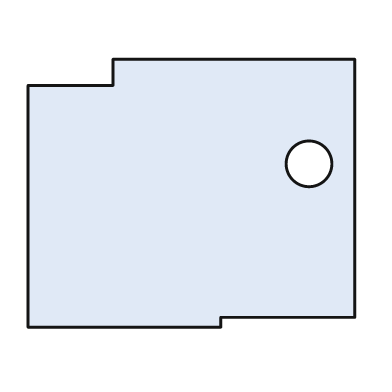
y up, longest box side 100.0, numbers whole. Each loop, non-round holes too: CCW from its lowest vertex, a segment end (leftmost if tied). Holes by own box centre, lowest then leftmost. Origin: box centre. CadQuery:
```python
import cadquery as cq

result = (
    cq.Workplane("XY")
    .moveTo(-50.0, -41.0)
    .lineTo(9.0, -41.0)
    .lineTo(9.0, -38.0)
    .lineTo(50.0, -38.0)
    .lineTo(50.0, 41.0)
    .lineTo(-24.0, 41.0)
    .lineTo(-24.0, 33.0)
    .lineTo(-50.0, 33.0)
    .close()
    .moveTo(36.0, 9.0)
    .circle(7.0)
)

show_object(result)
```